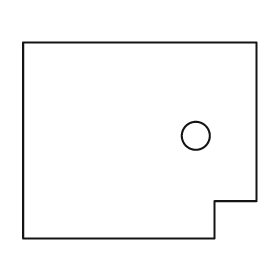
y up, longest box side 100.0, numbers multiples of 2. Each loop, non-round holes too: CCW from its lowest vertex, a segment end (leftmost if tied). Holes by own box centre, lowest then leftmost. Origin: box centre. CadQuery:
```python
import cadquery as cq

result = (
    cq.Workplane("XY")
    .moveTo(-50.0, -42.0)
    .lineTo(32.0, -42.0)
    .lineTo(32.0, -26.0)
    .lineTo(50.0, -26.0)
    .lineTo(50.0, 42.0)
    .lineTo(-50.0, 42.0)
    .close()
    .moveTo(24.0, 2.0)
    .circle(6.0)
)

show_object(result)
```